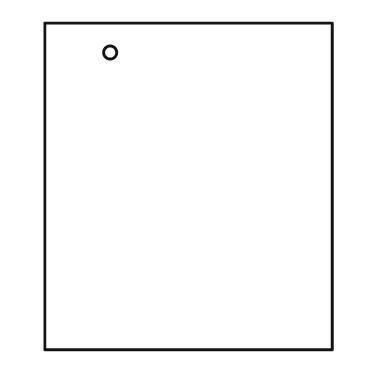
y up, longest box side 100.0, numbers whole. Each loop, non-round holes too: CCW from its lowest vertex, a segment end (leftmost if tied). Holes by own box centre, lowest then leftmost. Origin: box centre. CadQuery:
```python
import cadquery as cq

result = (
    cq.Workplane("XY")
    .moveTo(-44.0, -50.0)
    .lineTo(44.0, -50.0)
    .lineTo(44.0, 50.0)
    .lineTo(-44.0, 50.0)
    .close()
    .moveTo(-24.0, 41.0)
    .circle(2.0)
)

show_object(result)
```